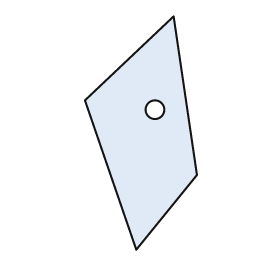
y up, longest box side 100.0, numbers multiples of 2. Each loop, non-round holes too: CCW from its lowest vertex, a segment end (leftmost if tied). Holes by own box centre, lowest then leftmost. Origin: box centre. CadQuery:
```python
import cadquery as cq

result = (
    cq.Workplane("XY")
    .moveTo(-2.0, -50.0)
    .lineTo(24.0, -18.0)
    .lineTo(14.0, 50.0)
    .lineTo(-24.0, 14.0)
    .close()
    .moveTo(6.0, 10.0)
    .circle(4.0)
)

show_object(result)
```